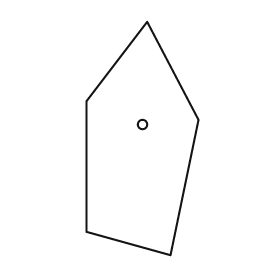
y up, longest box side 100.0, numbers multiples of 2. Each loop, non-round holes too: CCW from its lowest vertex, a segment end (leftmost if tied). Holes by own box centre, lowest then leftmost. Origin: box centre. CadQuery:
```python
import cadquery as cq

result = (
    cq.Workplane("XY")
    .moveTo(12.0, -50.0)
    .lineTo(24.0, 8.0)
    .lineTo(2.0, 50.0)
    .lineTo(-24.0, 16.0)
    .lineTo(-24.0, -40.0)
    .close()
    .moveTo(0.0, 6.0)
    .circle(2.0)
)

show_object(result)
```